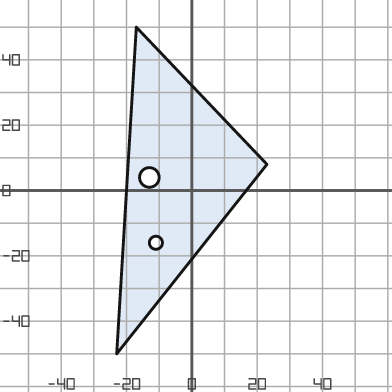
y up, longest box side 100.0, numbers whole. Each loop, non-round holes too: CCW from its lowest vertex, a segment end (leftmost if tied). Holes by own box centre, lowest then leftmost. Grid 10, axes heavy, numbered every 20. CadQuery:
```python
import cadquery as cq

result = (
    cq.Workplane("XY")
    .moveTo(-23.0, -50.0)
    .lineTo(23.0, 8.0)
    .lineTo(-17.0, 50.0)
    .close()
    .moveTo(-11.0, -16.0)
    .circle(2.0)
    .moveTo(-13.0, 4.0)
    .circle(3.0)
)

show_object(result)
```